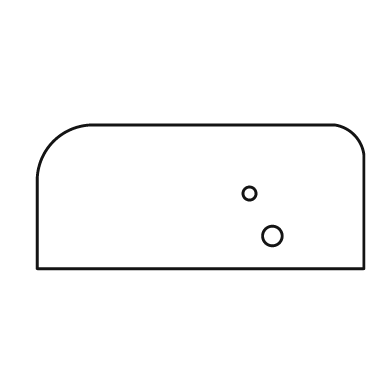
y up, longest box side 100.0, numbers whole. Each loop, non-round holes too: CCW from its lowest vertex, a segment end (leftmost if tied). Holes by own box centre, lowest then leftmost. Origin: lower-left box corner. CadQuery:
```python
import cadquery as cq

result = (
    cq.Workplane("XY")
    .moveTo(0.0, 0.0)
    .lineTo(100.0, 0.0)
    .lineTo(100.0, 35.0)
    .threePointArc((97.0, 41.0), (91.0, 44.0))
    .lineTo(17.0, 44.0)
    .threePointArc((5.0, 39.0), (0.0, 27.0))
    .close()
    .moveTo(72.0, 10.0)
    .circle(3.0)
    .moveTo(65.0, 23.0)
    .circle(2.0)
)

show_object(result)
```